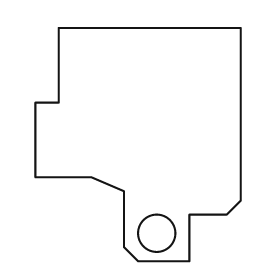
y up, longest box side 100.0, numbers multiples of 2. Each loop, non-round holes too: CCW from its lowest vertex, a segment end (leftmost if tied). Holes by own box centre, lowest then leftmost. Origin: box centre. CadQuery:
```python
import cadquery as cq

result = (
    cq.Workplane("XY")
    .moveTo(0.0, -50.0)
    .lineTo(22.0, -50.0)
    .lineTo(22.0, -30.0)
    .lineTo(38.0, -30.0)
    .lineTo(44.0, -24.0)
    .lineTo(44.0, 50.0)
    .lineTo(-34.0, 50.0)
    .lineTo(-34.0, 18.0)
    .lineTo(-44.0, 18.0)
    .lineTo(-44.0, -14.0)
    .lineTo(-20.0, -14.0)
    .lineTo(-6.0, -20.0)
    .lineTo(-6.0, -44.0)
    .close()
    .moveTo(8.0, -38.0)
    .circle(8.0)
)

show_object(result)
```